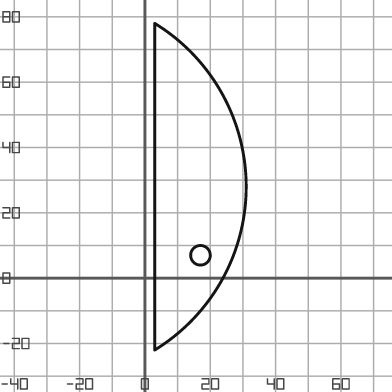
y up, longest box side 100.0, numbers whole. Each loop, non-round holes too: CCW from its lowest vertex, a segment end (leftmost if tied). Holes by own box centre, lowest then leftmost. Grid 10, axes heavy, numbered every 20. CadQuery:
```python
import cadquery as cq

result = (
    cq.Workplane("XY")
    .moveTo(3.0, -22.0)
    .threePointArc((31.0, 28.0), (3.0, 78.0))
    .close()
    .moveTo(17.0, 7.0)
    .circle(3.0)
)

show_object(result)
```